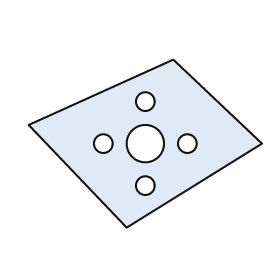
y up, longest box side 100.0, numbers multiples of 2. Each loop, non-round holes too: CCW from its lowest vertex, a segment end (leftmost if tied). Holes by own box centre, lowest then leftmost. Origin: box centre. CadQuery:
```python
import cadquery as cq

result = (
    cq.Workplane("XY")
    .moveTo(-8.0, -36.0)
    .lineTo(50.0, 0.0)
    .lineTo(12.0, 36.0)
    .lineTo(-50.0, 8.0)
    .close()
    .moveTo(0.0, -18.0)
    .circle(4.0)
    .moveTo(-18.0, 0.0)
    .circle(4.0)
    .moveTo(0.0, 0.0)
    .circle(8.0)
    .moveTo(18.0, 0.0)
    .circle(4.0)
    .moveTo(0.0, 18.0)
    .circle(4.0)
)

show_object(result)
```